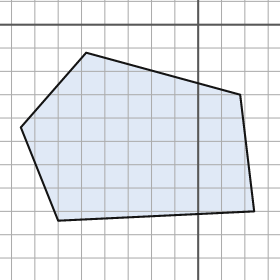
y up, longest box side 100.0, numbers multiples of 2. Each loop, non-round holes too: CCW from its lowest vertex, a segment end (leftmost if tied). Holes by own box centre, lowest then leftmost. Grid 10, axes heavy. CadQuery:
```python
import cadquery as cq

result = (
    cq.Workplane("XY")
    .moveTo(-60.0, -84.0)
    .lineTo(24.0, -80.0)
    .lineTo(18.0, -30.0)
    .lineTo(-48.0, -12.0)
    .lineTo(-76.0, -44.0)
    .close()
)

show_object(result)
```